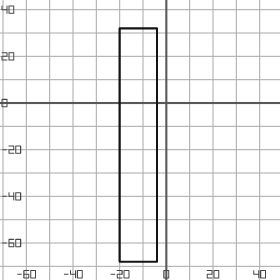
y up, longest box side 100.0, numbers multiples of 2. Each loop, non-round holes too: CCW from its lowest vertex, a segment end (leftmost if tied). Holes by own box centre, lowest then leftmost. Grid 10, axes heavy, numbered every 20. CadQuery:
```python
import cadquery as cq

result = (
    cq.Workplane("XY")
    .moveTo(-20.0, -68.0)
    .lineTo(-4.0, -68.0)
    .lineTo(-4.0, 32.0)
    .lineTo(-20.0, 32.0)
    .close()
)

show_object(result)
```